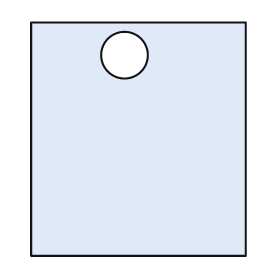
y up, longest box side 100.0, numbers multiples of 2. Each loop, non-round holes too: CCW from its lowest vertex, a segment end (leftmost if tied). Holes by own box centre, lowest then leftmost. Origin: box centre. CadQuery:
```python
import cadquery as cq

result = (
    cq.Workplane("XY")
    .moveTo(-46.0, -50.0)
    .lineTo(46.0, -50.0)
    .lineTo(46.0, 50.0)
    .lineTo(-46.0, 50.0)
    .close()
    .moveTo(-6.0, 36.0)
    .circle(10.0)
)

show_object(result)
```